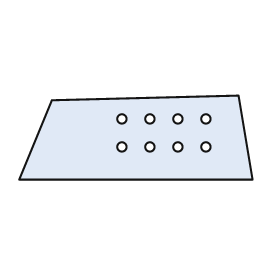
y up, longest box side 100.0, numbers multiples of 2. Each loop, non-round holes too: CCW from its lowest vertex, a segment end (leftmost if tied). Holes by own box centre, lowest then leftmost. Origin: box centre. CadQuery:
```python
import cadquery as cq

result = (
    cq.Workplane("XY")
    .moveTo(-50.0, -18.0)
    .lineTo(50.0, -18.0)
    .lineTo(44.0, 18.0)
    .lineTo(-36.0, 16.0)
    .close()
    .moveTo(-6.0, -4.0)
    .circle(2.0)
    .moveTo(6.0, -4.0)
    .circle(2.0)
    .moveTo(18.0, -4.0)
    .circle(2.0)
    .moveTo(30.0, -4.0)
    .circle(2.0)
    .moveTo(-6.0, 8.0)
    .circle(2.0)
    .moveTo(6.0, 8.0)
    .circle(2.0)
    .moveTo(18.0, 8.0)
    .circle(2.0)
    .moveTo(30.0, 8.0)
    .circle(2.0)
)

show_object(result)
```